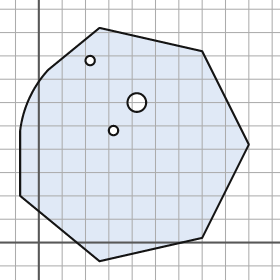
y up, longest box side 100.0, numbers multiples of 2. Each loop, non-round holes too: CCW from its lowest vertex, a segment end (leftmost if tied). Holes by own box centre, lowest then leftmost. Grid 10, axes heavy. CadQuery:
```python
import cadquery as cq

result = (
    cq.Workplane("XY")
    .moveTo(26.0, -8.0)
    .lineTo(70.0, 2.0)
    .lineTo(90.0, 42.0)
    .lineTo(70.0, 82.0)
    .lineTo(26.0, 92.0)
    .lineTo(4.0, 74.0)
    .threePointArc((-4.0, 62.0), (-8.0, 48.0))
    .lineTo(-8.0, 20.0)
    .close()
    .moveTo(32.0, 48.0)
    .circle(2.0)
    .moveTo(42.0, 60.0)
    .circle(4.0)
    .moveTo(22.0, 78.0)
    .circle(2.0)
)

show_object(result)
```